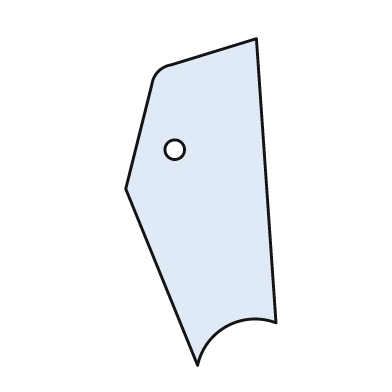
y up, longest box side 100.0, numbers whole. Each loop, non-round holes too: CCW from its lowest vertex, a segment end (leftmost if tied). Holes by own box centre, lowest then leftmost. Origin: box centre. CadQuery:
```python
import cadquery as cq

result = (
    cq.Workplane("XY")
    .moveTo(-1.0, -50.0)
    .threePointArc((8.0, -38.0), (23.0, -37.0))
    .lineTo(17.0, 50.0)
    .lineTo(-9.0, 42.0)
    .threePointArc((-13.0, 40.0), (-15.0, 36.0))
    .lineTo(-23.0, 4.0)
    .close()
    .moveTo(-8.0, 16.0)
    .circle(3.0)
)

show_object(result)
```